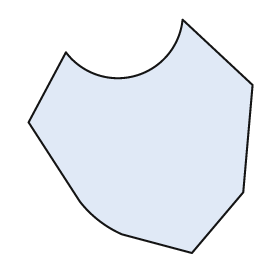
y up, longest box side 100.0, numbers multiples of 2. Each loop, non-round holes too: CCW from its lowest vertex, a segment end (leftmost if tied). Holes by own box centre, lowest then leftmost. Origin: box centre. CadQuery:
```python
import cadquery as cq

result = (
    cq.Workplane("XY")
    .moveTo(22.0, -50.0)
    .lineTo(44.0, -24.0)
    .lineTo(48.0, 22.0)
    .lineTo(18.0, 50.0)
    .threePointArc((-2.0, 26.0), (-32.0, 36.0))
    .lineTo(-48.0, 6.0)
    .lineTo(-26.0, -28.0)
    .threePointArc((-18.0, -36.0), (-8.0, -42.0))
    .close()
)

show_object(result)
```